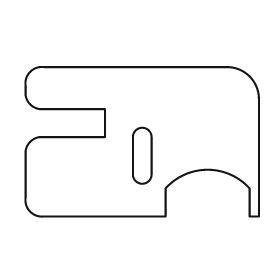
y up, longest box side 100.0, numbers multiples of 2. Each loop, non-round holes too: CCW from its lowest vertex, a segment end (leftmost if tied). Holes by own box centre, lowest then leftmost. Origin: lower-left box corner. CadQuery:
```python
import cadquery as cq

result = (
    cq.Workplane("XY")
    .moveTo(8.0, 0.0)
    .lineTo(60.0, 0.0)
    .lineTo(60.0, 12.0)
    .threePointArc((78.0, 20.0), (96.0, 12.0))
    .lineTo(96.0, 0.0)
    .lineTo(100.0, 0.0)
    .lineTo(100.0, 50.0)
    .threePointArc((96.0, 60.0), (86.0, 64.0))
    .lineTo(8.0, 64.0)
    .threePointArc((2.0, 62.0), (0.0, 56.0))
    .lineTo(0.0, 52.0)
    .threePointArc((2.0, 48.0), (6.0, 46.0))
    .lineTo(34.0, 46.0)
    .lineTo(34.0, 34.0)
    .lineTo(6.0, 34.0)
    .threePointArc((2.0, 32.0), (0.0, 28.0))
    .lineTo(0.0, 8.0)
    .threePointArc((2.0, 2.0), (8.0, 0.0))
    .close()
    .moveTo(46.0, 18.0)
    .threePointArc((50.0, 14.0), (54.0, 18.0))
    .lineTo(54.0, 34.0)
    .threePointArc((50.0, 38.0), (46.0, 34.0))
    .close()
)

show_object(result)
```